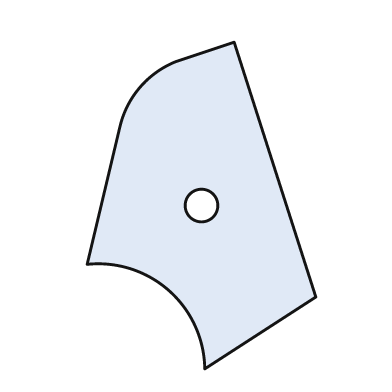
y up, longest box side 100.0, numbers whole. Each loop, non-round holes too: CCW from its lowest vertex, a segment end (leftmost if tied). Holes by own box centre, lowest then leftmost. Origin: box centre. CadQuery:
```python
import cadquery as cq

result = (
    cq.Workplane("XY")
    .moveTo(1.0, -50.0)
    .lineTo(35.0, -28.0)
    .lineTo(10.0, 50.0)
    .lineTo(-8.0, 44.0)
    .threePointArc((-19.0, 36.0), (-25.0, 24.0))
    .lineTo(-35.0, -18.0)
    .threePointArc((-10.0, -26.0), (1.0, -50.0))
    .close()
    .moveTo(0.0, 0.0)
    .circle(5.0)
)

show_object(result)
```